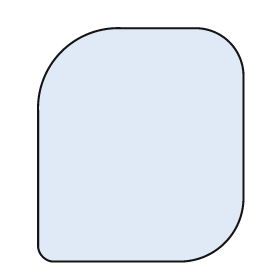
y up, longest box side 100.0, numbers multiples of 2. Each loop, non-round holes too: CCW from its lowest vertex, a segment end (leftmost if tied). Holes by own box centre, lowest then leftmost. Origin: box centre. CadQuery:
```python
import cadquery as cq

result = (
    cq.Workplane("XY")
    .moveTo(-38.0, -50.0)
    .lineTo(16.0, -50.0)
    .threePointArc((36.0, -42.0), (44.0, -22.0))
    .lineTo(44.0, 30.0)
    .threePointArc((38.0, 44.0), (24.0, 50.0))
    .lineTo(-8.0, 50.0)
    .threePointArc((-34.0, 40.0), (-44.0, 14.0))
    .lineTo(-44.0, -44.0)
    .threePointArc((-42.0, -48.0), (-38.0, -50.0))
    .close()
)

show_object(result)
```